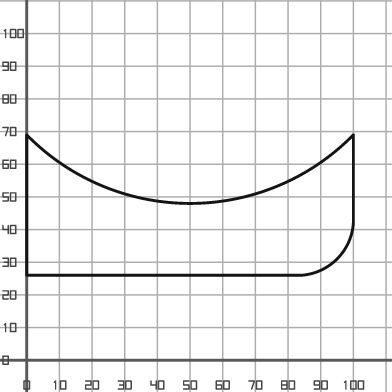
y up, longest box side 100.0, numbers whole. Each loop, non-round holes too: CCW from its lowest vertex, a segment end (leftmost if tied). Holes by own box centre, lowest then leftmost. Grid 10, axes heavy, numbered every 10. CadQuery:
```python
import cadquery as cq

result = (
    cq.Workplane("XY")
    .moveTo(0.0, 26.0)
    .lineTo(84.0, 26.0)
    .threePointArc((95.0, 31.0), (100.0, 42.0))
    .lineTo(100.0, 69.0)
    .threePointArc((50.0, 48.0), (0.0, 69.0))
    .close()
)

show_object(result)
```